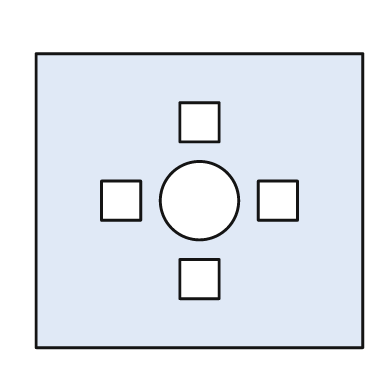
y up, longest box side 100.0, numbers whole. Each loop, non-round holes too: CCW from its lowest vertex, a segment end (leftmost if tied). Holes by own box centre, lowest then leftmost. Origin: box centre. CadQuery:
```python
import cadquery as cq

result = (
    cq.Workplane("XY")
    .moveTo(-50.0, -45.0)
    .lineTo(50.0, -45.0)
    .lineTo(50.0, 45.0)
    .lineTo(-50.0, 45.0)
    .close()
    .moveTo(-6.0, -30.0)
    .lineTo(6.0, -30.0)
    .lineTo(6.0, -18.0)
    .lineTo(-6.0, -18.0)
    .close()
    .moveTo(-30.0, -6.0)
    .lineTo(-18.0, -6.0)
    .lineTo(-18.0, 6.0)
    .lineTo(-30.0, 6.0)
    .close()
    .moveTo(0.0, 0.0)
    .circle(12.0)
    .moveTo(18.0, -6.0)
    .lineTo(30.0, -6.0)
    .lineTo(30.0, 6.0)
    .lineTo(18.0, 6.0)
    .close()
    .moveTo(-6.0, 18.0)
    .lineTo(6.0, 18.0)
    .lineTo(6.0, 30.0)
    .lineTo(-6.0, 30.0)
    .close()
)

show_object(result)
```